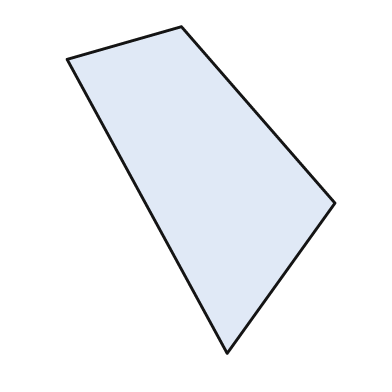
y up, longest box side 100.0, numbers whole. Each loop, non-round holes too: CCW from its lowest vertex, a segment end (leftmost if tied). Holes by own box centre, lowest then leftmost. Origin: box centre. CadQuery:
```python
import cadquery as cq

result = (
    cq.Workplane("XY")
    .moveTo(8.0, -50.0)
    .lineTo(41.0, -4.0)
    .lineTo(-6.0, 50.0)
    .lineTo(-41.0, 40.0)
    .close()
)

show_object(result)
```